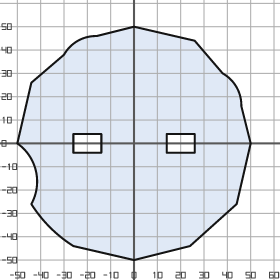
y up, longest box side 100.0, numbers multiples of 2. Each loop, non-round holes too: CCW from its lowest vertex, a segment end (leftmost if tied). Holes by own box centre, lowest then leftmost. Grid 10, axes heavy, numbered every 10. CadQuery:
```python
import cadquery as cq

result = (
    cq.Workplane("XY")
    .moveTo(0.0, -50.0)
    .lineTo(24.0, -44.0)
    .lineTo(44.0, -26.0)
    .lineTo(50.0, 0.0)
    .lineTo(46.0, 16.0)
    .threePointArc((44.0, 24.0), (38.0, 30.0))
    .lineTo(26.0, 44.0)
    .lineTo(0.0, 50.0)
    .lineTo(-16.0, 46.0)
    .threePointArc((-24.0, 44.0), (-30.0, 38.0))
    .lineTo(-44.0, 26.0)
    .lineTo(-50.0, 0.0)
    .threePointArc((-42.0, -12.0), (-44.0, -26.0))
    .threePointArc((-36.0, -36.0), (-26.0, -44.0))
    .close()
    .moveTo(-26.0, -4.0)
    .lineTo(-14.0, -4.0)
    .lineTo(-14.0, 4.0)
    .lineTo(-26.0, 4.0)
    .close()
    .moveTo(14.0, -4.0)
    .lineTo(26.0, -4.0)
    .lineTo(26.0, 4.0)
    .lineTo(14.0, 4.0)
    .close()
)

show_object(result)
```